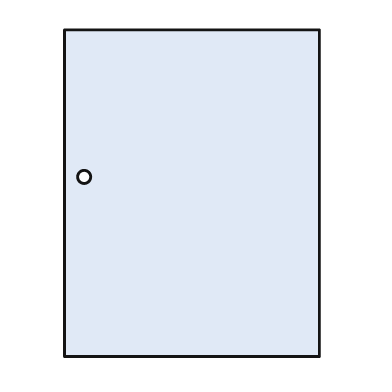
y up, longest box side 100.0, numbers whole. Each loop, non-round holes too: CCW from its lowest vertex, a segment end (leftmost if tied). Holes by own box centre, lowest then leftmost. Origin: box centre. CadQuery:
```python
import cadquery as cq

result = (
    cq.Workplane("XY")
    .moveTo(-39.0, -50.0)
    .lineTo(39.0, -50.0)
    .lineTo(39.0, 50.0)
    .lineTo(-39.0, 50.0)
    .close()
    .moveTo(-33.0, 5.0)
    .circle(2.0)
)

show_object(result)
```